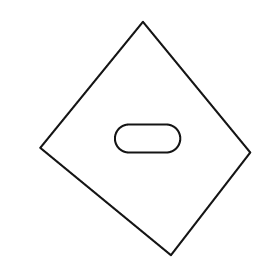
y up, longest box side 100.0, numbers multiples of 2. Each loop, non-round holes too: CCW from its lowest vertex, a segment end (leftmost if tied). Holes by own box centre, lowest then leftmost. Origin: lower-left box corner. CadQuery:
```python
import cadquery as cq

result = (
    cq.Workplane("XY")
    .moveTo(56.0, 0.0)
    .lineTo(90.0, 44.0)
    .lineTo(44.0, 100.0)
    .lineTo(0.0, 46.0)
    .close()
    .moveTo(38.0, 44.0)
    .lineTo(54.0, 44.0)
    .threePointArc((60.0, 50.0), (54.0, 56.0))
    .lineTo(38.0, 56.0)
    .threePointArc((32.0, 50.0), (38.0, 44.0))
    .close()
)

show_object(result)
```